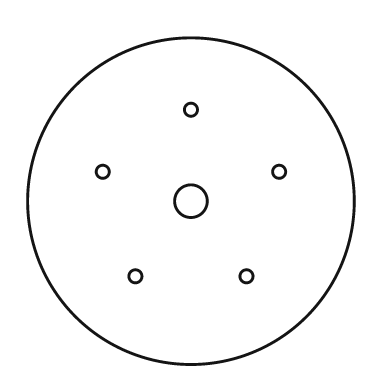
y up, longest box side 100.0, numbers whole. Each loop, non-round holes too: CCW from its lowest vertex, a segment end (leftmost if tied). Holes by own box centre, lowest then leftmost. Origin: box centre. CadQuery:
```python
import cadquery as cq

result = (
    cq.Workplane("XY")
    .moveTo(0.0, 0.0)
    .circle(50.0)
    .moveTo(-17.0, -23.0)
    .circle(2.0)
    .moveTo(17.0, -23.0)
    .circle(2.0)
    .moveTo(0.0, 0.0)
    .circle(5.0)
    .moveTo(-27.0, 9.0)
    .circle(2.0)
    .moveTo(27.0, 9.0)
    .circle(2.0)
    .moveTo(0.0, 28.0)
    .circle(2.0)
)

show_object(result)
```